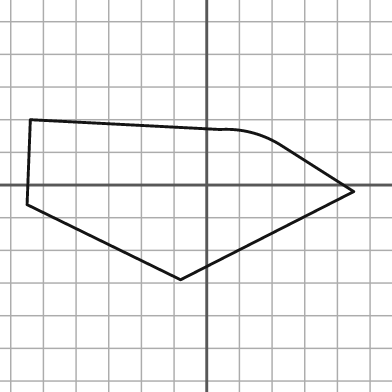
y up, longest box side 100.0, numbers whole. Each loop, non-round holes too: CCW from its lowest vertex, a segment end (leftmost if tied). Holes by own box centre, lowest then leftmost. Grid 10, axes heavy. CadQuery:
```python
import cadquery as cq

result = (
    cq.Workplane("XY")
    .moveTo(-8.0, -29.0)
    .lineTo(45.0, -2.0)
    .lineTo(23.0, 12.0)
    .threePointArc((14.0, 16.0), (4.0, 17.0))
    .lineTo(-54.0, 20.0)
    .lineTo(-55.0, -6.0)
    .close()
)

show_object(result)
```